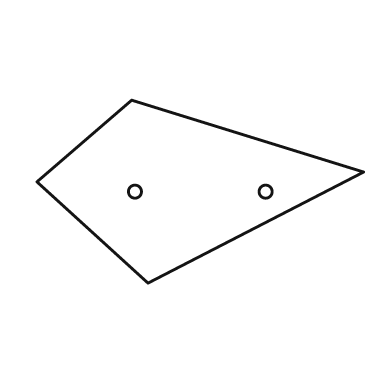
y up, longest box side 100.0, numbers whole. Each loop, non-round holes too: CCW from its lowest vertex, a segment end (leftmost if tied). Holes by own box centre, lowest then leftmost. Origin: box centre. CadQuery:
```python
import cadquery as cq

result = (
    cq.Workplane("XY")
    .moveTo(-16.0, -28.0)
    .lineTo(50.0, 6.0)
    .lineTo(-21.0, 28.0)
    .lineTo(-50.0, 3.0)
    .close()
    .moveTo(-20.0, 0.0)
    .circle(2.0)
    .moveTo(20.0, 0.0)
    .circle(2.0)
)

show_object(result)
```